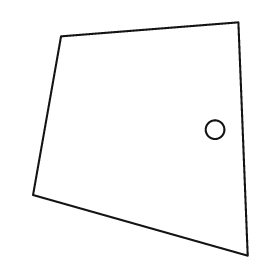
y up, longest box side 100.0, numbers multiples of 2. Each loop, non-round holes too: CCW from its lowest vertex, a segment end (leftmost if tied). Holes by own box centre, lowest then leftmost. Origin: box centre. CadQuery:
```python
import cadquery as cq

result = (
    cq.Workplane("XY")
    .moveTo(46.0, -50.0)
    .lineTo(42.0, 50.0)
    .lineTo(-34.0, 44.0)
    .lineTo(-46.0, -24.0)
    .close()
    .moveTo(32.0, 4.0)
    .circle(4.0)
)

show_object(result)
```